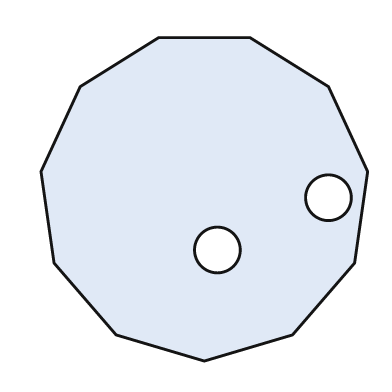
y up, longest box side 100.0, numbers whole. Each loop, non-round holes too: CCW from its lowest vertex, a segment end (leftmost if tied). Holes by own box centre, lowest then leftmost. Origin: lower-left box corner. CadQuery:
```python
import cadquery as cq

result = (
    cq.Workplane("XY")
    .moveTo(50.0, 0.0)
    .lineTo(77.0, 8.0)
    .lineTo(96.0, 30.0)
    .lineTo(100.0, 58.0)
    .lineTo(88.0, 84.0)
    .lineTo(64.0, 99.0)
    .lineTo(36.0, 99.0)
    .lineTo(12.0, 84.0)
    .lineTo(0.0, 58.0)
    .lineTo(4.0, 30.0)
    .lineTo(23.0, 8.0)
    .close()
    .moveTo(54.0, 34.0)
    .circle(7.0)
    .moveTo(88.0, 50.0)
    .circle(7.0)
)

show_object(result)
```